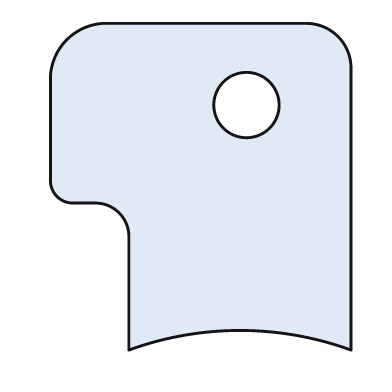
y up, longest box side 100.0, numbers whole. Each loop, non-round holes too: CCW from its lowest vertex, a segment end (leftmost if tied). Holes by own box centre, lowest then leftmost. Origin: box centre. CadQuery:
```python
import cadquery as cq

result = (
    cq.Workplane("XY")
    .moveTo(-22.0, -50.0)
    .threePointArc((12.0, -44.0), (46.0, -50.0))
    .lineTo(46.0, 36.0)
    .threePointArc((42.0, 46.0), (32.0, 50.0))
    .lineTo(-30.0, 50.0)
    .threePointArc((-41.0, 45.0), (-46.0, 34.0))
    .lineTo(-46.0, 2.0)
    .threePointArc((-44.0, -3.0), (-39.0, -5.0))
    .lineTo(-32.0, -5.0)
    .threePointArc((-25.0, -8.0), (-22.0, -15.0))
    .close()
    .moveTo(14.0, 25.0)
    .circle(10.0)
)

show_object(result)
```